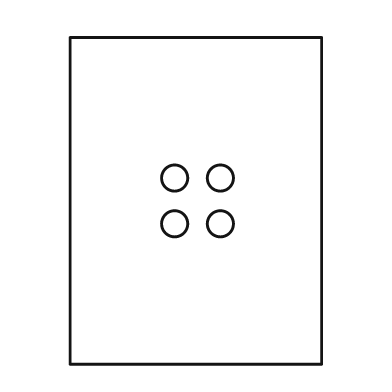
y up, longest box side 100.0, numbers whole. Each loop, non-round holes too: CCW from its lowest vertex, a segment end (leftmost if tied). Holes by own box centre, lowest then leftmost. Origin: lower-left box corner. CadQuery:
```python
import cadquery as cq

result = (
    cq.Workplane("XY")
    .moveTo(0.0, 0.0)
    .lineTo(77.0, 0.0)
    .lineTo(77.0, 100.0)
    .lineTo(0.0, 100.0)
    .close()
    .moveTo(32.0, 43.0)
    .circle(4.0)
    .moveTo(46.0, 43.0)
    .circle(4.0)
    .moveTo(32.0, 57.0)
    .circle(4.0)
    .moveTo(46.0, 57.0)
    .circle(4.0)
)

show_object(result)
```